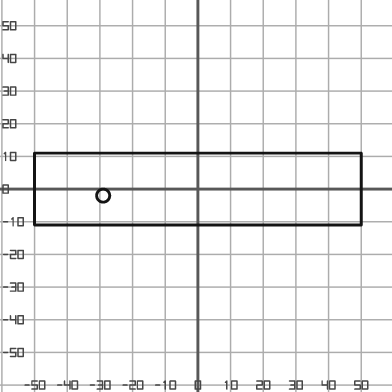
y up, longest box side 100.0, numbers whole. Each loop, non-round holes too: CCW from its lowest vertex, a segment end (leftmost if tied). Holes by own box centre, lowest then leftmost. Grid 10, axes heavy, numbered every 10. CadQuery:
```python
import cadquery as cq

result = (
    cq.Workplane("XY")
    .moveTo(-50.0, -11.0)
    .lineTo(50.0, -11.0)
    .lineTo(50.0, 11.0)
    .lineTo(-50.0, 11.0)
    .close()
    .moveTo(-29.0, -2.0)
    .circle(2.0)
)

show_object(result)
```